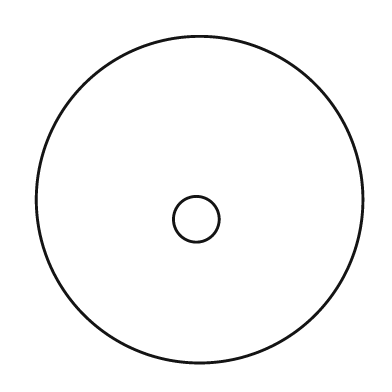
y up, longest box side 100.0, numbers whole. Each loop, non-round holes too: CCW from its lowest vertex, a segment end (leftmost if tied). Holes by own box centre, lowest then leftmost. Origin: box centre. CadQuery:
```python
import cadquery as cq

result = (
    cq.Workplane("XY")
    .moveTo(0.0, 0.0)
    .circle(50.0)
    .moveTo(-1.0, -6.0)
    .circle(7.0)
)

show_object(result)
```